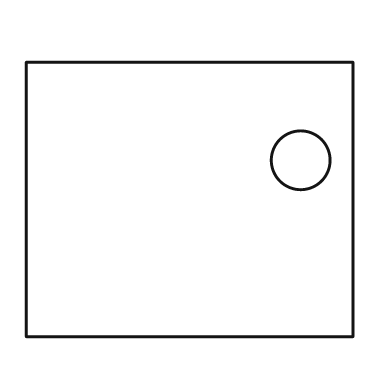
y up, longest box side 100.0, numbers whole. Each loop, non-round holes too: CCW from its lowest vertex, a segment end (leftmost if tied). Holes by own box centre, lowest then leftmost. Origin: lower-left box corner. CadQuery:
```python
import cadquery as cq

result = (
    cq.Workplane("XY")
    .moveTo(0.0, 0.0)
    .lineTo(100.0, 0.0)
    .lineTo(100.0, 84.0)
    .lineTo(0.0, 84.0)
    .close()
    .moveTo(84.0, 54.0)
    .circle(9.0)
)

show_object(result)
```